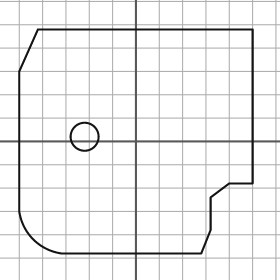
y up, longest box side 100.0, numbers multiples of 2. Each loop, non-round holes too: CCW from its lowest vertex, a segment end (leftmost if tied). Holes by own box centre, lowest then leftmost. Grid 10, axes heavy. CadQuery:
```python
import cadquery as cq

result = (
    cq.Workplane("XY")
    .moveTo(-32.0, -48.0)
    .lineTo(28.0, -48.0)
    .lineTo(32.0, -38.0)
    .lineTo(32.0, -24.0)
    .lineTo(40.0, -18.0)
    .lineTo(50.0, -18.0)
    .lineTo(50.0, 48.0)
    .lineTo(-42.0, 48.0)
    .lineTo(-50.0, 30.0)
    .lineTo(-50.0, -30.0)
    .threePointArc((-44.0, -42.0), (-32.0, -48.0))
    .close()
    .moveTo(-22.0, 2.0)
    .circle(6.0)
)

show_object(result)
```